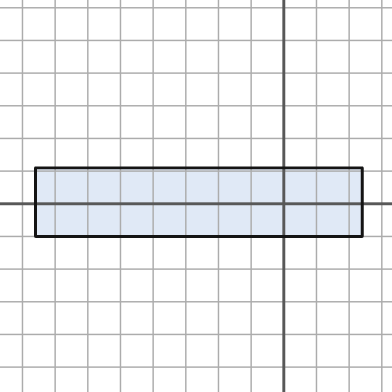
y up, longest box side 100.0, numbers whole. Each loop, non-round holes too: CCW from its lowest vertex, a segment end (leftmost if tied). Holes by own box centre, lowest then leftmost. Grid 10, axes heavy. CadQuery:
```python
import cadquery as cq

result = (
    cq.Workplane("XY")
    .moveTo(-76.0, -10.0)
    .lineTo(24.0, -10.0)
    .lineTo(24.0, 11.0)
    .lineTo(-76.0, 11.0)
    .close()
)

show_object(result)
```